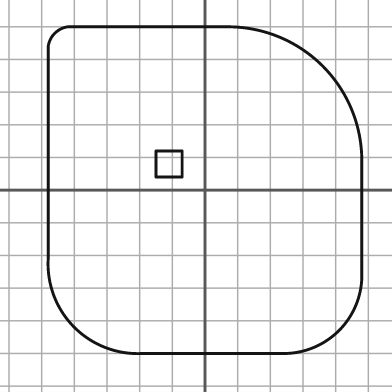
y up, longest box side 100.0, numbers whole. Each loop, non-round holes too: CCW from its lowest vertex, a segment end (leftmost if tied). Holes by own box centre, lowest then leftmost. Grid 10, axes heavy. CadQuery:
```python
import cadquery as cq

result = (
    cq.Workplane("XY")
    .moveTo(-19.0, -50.0)
    .lineTo(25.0, -50.0)
    .threePointArc((41.0, -43.0), (48.0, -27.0))
    .lineTo(48.0, 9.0)
    .threePointArc((36.0, 38.0), (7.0, 50.0))
    .lineTo(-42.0, 50.0)
    .threePointArc((-46.0, 48.0), (-48.0, 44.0))
    .lineTo(-48.0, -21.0)
    .threePointArc((-40.0, -42.0), (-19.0, -50.0))
    .close()
    .moveTo(-15.0, 4.0)
    .lineTo(-7.0, 4.0)
    .lineTo(-7.0, 12.0)
    .lineTo(-15.0, 12.0)
    .close()
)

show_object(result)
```